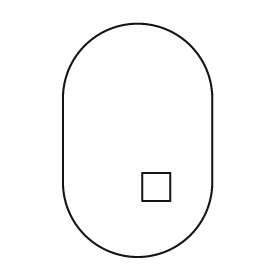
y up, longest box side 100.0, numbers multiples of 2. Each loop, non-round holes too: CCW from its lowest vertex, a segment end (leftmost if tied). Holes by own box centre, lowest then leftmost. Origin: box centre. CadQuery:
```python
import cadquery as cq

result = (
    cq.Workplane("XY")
    .moveTo(-32.0, -18.0)
    .threePointArc((0.0, -50.0), (32.0, -18.0))
    .lineTo(32.0, 18.0)
    .threePointArc((0.0, 50.0), (-32.0, 18.0))
    .close()
    .moveTo(2.0, -26.0)
    .lineTo(14.0, -26.0)
    .lineTo(14.0, -14.0)
    .lineTo(2.0, -14.0)
    .close()
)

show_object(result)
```